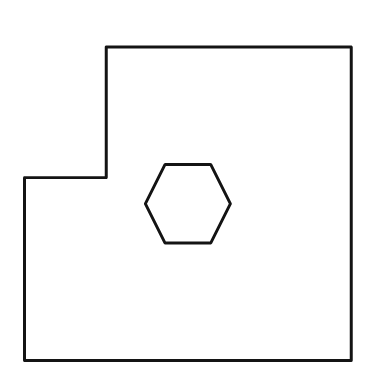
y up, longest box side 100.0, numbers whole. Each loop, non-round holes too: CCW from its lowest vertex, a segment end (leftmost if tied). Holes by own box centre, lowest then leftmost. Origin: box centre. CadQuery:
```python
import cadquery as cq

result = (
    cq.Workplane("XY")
    .moveTo(-50.0, -48.0)
    .lineTo(50.0, -48.0)
    .lineTo(50.0, 48.0)
    .lineTo(-25.0, 48.0)
    .lineTo(-25.0, 8.0)
    .lineTo(-50.0, 8.0)
    .close()
    .moveTo(-7.0, -12.0)
    .lineTo(7.0, -12.0)
    .lineTo(13.0, 0.0)
    .lineTo(7.0, 12.0)
    .lineTo(-7.0, 12.0)
    .lineTo(-13.0, 0.0)
    .close()
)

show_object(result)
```